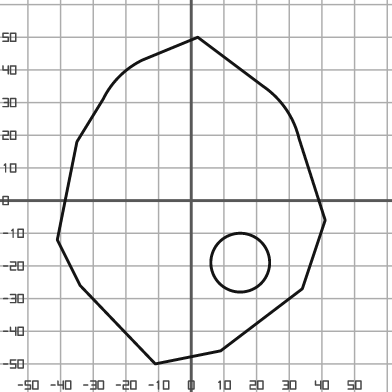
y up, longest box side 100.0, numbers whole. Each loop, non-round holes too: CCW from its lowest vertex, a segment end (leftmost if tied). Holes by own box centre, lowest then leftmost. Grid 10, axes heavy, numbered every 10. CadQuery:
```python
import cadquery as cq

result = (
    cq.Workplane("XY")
    .moveTo(-11.0, -50.0)
    .lineTo(9.0, -46.0)
    .lineTo(34.0, -27.0)
    .lineTo(41.0, -6.0)
    .lineTo(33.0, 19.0)
    .threePointArc((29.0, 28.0), (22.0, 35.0))
    .lineTo(2.0, 50.0)
    .lineTo(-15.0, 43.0)
    .threePointArc((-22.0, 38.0), (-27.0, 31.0))
    .lineTo(-35.0, 18.0)
    .lineTo(-41.0, -12.0)
    .lineTo(-34.0, -26.0)
    .close()
    .moveTo(15.0, -19.0)
    .circle(9.0)
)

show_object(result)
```